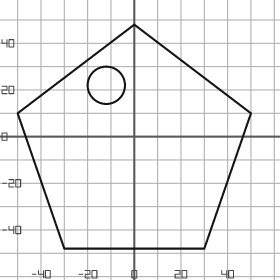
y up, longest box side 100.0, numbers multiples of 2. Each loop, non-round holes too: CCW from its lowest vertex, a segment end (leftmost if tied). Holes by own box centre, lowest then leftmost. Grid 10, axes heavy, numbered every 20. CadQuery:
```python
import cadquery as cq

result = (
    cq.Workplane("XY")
    .moveTo(-30.0, -48.0)
    .lineTo(30.0, -48.0)
    .lineTo(50.0, 10.0)
    .lineTo(0.0, 48.0)
    .lineTo(-50.0, 10.0)
    .close()
    .moveTo(-12.0, 22.0)
    .circle(8.0)
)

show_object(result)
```